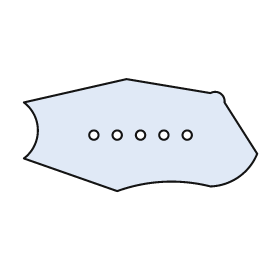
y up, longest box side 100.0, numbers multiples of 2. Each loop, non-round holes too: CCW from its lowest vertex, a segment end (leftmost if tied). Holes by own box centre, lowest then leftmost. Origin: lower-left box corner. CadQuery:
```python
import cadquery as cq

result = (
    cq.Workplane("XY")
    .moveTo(40.0, 0.0)
    .threePointArc((60.0, 4.0), (80.0, 2.0))
    .threePointArc((92.0, 6.0), (100.0, 16.0))
    .lineTo(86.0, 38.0)
    .threePointArc((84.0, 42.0), (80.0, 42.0))
    .lineTo(44.0, 48.0)
    .lineTo(0.0, 38.0)
    .threePointArc((6.0, 26.0), (0.0, 14.0))
    .close()
    .moveTo(30.0, 24.0)
    .circle(2.0)
    .moveTo(40.0, 24.0)
    .circle(2.0)
    .moveTo(50.0, 24.0)
    .circle(2.0)
    .moveTo(60.0, 24.0)
    .circle(2.0)
    .moveTo(70.0, 24.0)
    .circle(2.0)
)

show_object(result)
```